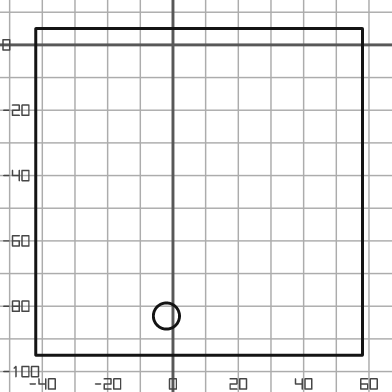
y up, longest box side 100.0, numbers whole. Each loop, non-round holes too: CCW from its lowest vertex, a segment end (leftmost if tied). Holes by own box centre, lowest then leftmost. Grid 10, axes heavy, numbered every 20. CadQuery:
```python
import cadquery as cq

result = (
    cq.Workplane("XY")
    .moveTo(-42.0, -95.0)
    .lineTo(58.0, -95.0)
    .lineTo(58.0, 5.0)
    .lineTo(-42.0, 5.0)
    .close()
    .moveTo(-2.0, -83.0)
    .circle(4.0)
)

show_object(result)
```